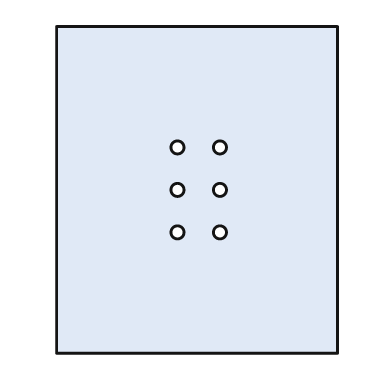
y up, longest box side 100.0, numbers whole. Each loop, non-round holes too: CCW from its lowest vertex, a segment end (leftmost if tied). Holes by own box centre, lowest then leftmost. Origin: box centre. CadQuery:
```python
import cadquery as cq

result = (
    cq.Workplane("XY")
    .moveTo(-43.0, -50.0)
    .lineTo(43.0, -50.0)
    .lineTo(43.0, 50.0)
    .lineTo(-43.0, 50.0)
    .close()
    .moveTo(-6.0, -13.0)
    .circle(2.0)
    .moveTo(7.0, -13.0)
    .circle(2.0)
    .moveTo(-6.0, 0.0)
    .circle(2.0)
    .moveTo(7.0, 0.0)
    .circle(2.0)
    .moveTo(-6.0, 13.0)
    .circle(2.0)
    .moveTo(7.0, 13.0)
    .circle(2.0)
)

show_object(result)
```